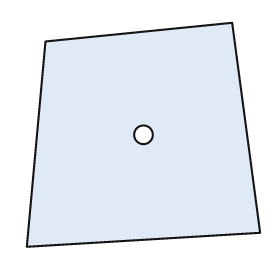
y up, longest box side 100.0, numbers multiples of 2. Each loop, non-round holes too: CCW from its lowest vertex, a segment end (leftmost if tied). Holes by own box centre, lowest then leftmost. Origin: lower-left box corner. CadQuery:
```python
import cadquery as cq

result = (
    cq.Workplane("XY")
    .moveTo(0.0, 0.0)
    .lineTo(100.0, 6.0)
    .lineTo(88.0, 96.0)
    .lineTo(8.0, 88.0)
    .close()
    .moveTo(50.0, 48.0)
    .circle(4.0)
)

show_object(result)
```